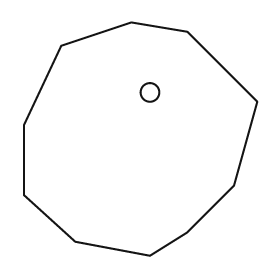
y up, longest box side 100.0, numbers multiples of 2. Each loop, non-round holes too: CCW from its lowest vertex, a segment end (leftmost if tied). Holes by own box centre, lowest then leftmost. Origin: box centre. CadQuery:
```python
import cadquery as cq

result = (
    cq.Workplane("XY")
    .moveTo(4.0, -50.0)
    .lineTo(20.0, -40.0)
    .lineTo(40.0, -20.0)
    .lineTo(50.0, 16.0)
    .lineTo(20.0, 46.0)
    .lineTo(-4.0, 50.0)
    .lineTo(-34.0, 40.0)
    .lineTo(-50.0, 6.0)
    .lineTo(-50.0, -24.0)
    .lineTo(-28.0, -44.0)
    .close()
    .moveTo(4.0, 20.0)
    .circle(4.0)
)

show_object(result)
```